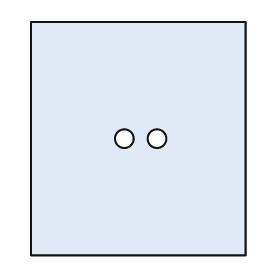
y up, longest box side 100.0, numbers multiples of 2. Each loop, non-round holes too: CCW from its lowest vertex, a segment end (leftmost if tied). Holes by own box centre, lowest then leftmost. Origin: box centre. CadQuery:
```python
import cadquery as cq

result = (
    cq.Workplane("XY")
    .moveTo(-46.0, -50.0)
    .lineTo(46.0, -50.0)
    .lineTo(46.0, 50.0)
    .lineTo(-46.0, 50.0)
    .close()
    .moveTo(-6.0, 0.0)
    .circle(4.0)
    .moveTo(8.0, 0.0)
    .circle(4.0)
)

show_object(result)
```